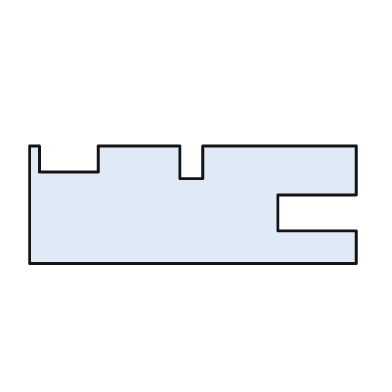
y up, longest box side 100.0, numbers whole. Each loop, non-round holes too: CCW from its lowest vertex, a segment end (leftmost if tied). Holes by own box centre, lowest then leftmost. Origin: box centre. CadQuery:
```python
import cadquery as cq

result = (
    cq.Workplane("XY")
    .moveTo(-50.0, -18.0)
    .lineTo(50.0, -18.0)
    .lineTo(50.0, -8.0)
    .lineTo(26.0, -8.0)
    .lineTo(26.0, 3.0)
    .lineTo(50.0, 3.0)
    .lineTo(50.0, 18.0)
    .lineTo(3.0, 18.0)
    .lineTo(3.0, 8.0)
    .lineTo(-4.0, 8.0)
    .lineTo(-4.0, 18.0)
    .lineTo(-29.0, 18.0)
    .lineTo(-29.0, 10.0)
    .lineTo(-47.0, 10.0)
    .lineTo(-47.0, 18.0)
    .lineTo(-50.0, 18.0)
    .close()
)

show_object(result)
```